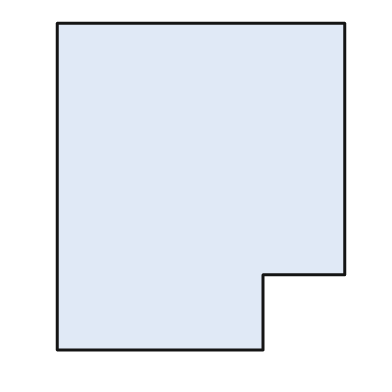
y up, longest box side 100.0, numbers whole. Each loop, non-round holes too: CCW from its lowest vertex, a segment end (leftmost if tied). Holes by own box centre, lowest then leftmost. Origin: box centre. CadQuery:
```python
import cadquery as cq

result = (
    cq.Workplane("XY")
    .moveTo(-44.0, -50.0)
    .lineTo(19.0, -50.0)
    .lineTo(19.0, -27.0)
    .lineTo(44.0, -27.0)
    .lineTo(44.0, 50.0)
    .lineTo(-44.0, 50.0)
    .close()
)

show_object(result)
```